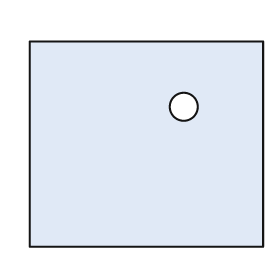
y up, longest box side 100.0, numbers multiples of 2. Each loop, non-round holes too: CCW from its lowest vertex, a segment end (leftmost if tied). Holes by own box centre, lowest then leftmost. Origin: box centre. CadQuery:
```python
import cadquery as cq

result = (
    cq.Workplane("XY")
    .moveTo(-50.0, -44.0)
    .lineTo(50.0, -44.0)
    .lineTo(50.0, 44.0)
    .lineTo(-50.0, 44.0)
    .close()
    .moveTo(16.0, 16.0)
    .circle(6.0)
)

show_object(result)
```